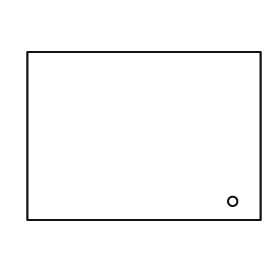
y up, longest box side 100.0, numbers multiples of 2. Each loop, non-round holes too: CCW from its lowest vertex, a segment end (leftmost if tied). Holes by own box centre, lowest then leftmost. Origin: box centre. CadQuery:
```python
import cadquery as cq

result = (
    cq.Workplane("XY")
    .moveTo(-50.0, -36.0)
    .lineTo(50.0, -36.0)
    .lineTo(50.0, 36.0)
    .lineTo(-50.0, 36.0)
    .close()
    .moveTo(38.0, -28.0)
    .circle(2.0)
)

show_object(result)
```